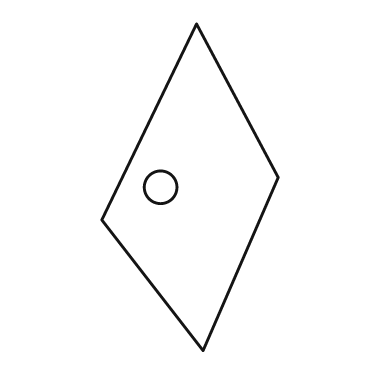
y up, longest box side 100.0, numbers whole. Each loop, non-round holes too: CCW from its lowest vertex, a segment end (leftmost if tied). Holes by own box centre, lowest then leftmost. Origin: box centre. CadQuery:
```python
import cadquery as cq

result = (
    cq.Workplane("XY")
    .moveTo(4.0, -50.0)
    .lineTo(27.0, 3.0)
    .lineTo(2.0, 50.0)
    .lineTo(-27.0, -10.0)
    .close()
    .moveTo(-9.0, 0.0)
    .circle(5.0)
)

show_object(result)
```